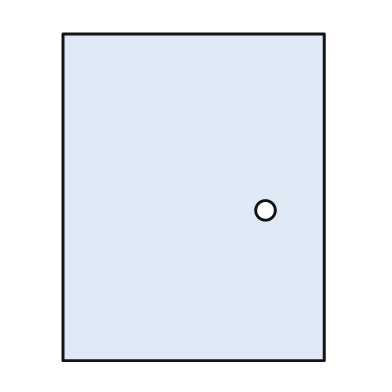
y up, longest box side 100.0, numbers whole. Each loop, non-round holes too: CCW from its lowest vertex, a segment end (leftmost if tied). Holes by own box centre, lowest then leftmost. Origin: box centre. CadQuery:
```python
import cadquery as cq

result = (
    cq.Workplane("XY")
    .moveTo(-40.0, -50.0)
    .lineTo(40.0, -50.0)
    .lineTo(40.0, 50.0)
    .lineTo(-40.0, 50.0)
    .close()
    .moveTo(22.0, -4.0)
    .circle(3.0)
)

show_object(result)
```